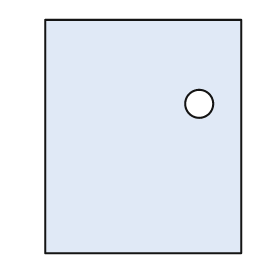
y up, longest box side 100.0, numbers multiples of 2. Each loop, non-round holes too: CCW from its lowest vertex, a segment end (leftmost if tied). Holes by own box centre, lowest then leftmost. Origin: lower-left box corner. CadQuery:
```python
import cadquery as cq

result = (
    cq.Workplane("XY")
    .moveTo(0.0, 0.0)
    .lineTo(84.0, 0.0)
    .lineTo(84.0, 100.0)
    .lineTo(0.0, 100.0)
    .close()
    .moveTo(66.0, 64.0)
    .circle(6.0)
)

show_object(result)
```